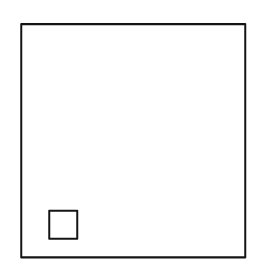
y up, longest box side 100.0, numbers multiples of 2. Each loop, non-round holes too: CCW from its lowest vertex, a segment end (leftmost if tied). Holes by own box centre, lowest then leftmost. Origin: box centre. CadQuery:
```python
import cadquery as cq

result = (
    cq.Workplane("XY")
    .moveTo(-48.0, -50.0)
    .lineTo(48.0, -50.0)
    .lineTo(48.0, 50.0)
    .lineTo(-48.0, 50.0)
    .close()
    .moveTo(-36.0, -42.0)
    .lineTo(-24.0, -42.0)
    .lineTo(-24.0, -30.0)
    .lineTo(-36.0, -30.0)
    .close()
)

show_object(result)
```